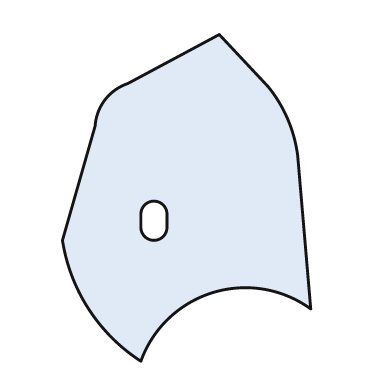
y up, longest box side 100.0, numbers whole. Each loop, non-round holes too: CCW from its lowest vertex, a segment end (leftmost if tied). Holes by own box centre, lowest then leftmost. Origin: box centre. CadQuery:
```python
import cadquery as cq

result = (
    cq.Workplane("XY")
    .moveTo(-14.0, -50.0)
    .threePointArc((8.0, -29.0), (38.0, -34.0))
    .lineTo(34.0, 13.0)
    .threePointArc((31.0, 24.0), (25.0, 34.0))
    .lineTo(10.0, 50.0)
    .lineTo(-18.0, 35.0)
    .threePointArc((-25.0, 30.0), (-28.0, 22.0))
    .lineTo(-38.0, -13.0)
    .threePointArc((-30.0, -34.0), (-14.0, -50.0))
    .close()
    .moveTo(-14.0, -9.0)
    .threePointArc((-10.0, -13.0), (-6.0, -9.0))
    .lineTo(-6.0, -5.0)
    .threePointArc((-10.0, -1.0), (-14.0, -5.0))
    .close()
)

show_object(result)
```